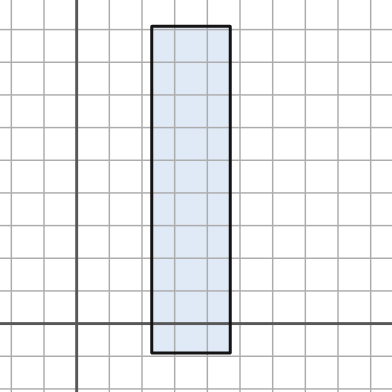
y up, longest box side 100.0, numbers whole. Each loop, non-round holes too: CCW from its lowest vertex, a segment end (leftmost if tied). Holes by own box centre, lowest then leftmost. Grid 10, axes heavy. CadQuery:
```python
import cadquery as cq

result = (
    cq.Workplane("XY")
    .moveTo(23.0, -9.0)
    .lineTo(47.0, -9.0)
    .lineTo(47.0, 91.0)
    .lineTo(23.0, 91.0)
    .close()
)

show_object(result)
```